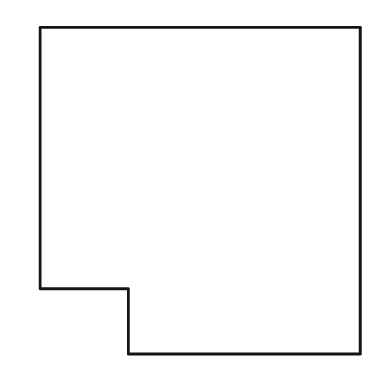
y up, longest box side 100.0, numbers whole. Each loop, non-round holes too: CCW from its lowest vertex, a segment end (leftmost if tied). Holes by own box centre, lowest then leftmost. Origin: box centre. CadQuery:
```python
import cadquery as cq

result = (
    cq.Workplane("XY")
    .moveTo(-22.0, -50.0)
    .lineTo(49.0, -50.0)
    .lineTo(49.0, 50.0)
    .lineTo(-49.0, 50.0)
    .lineTo(-49.0, -30.0)
    .lineTo(-22.0, -30.0)
    .close()
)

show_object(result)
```